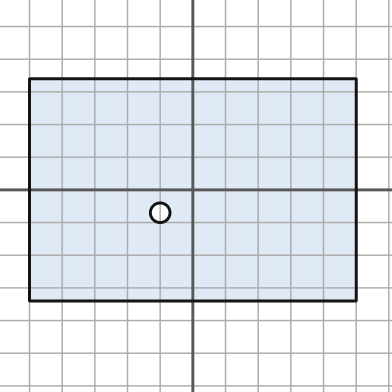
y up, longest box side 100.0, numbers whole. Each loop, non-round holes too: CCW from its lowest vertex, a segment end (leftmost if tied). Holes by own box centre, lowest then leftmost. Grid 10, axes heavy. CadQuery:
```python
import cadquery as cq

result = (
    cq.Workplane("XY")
    .moveTo(-50.0, -34.0)
    .lineTo(50.0, -34.0)
    .lineTo(50.0, 34.0)
    .lineTo(-50.0, 34.0)
    .close()
    .moveTo(-10.0, -7.0)
    .circle(3.0)
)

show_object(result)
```